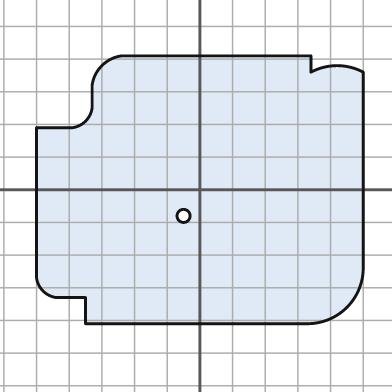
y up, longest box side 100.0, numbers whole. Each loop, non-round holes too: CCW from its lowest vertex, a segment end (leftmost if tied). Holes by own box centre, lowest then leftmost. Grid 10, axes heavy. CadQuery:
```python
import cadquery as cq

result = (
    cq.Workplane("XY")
    .moveTo(-35.0, -41.0)
    .lineTo(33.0, -41.0)
    .threePointArc((45.0, -36.0), (50.0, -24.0))
    .lineTo(50.0, 36.0)
    .threePointArc((42.0, 38.0), (34.0, 36.0))
    .lineTo(34.0, 41.0)
    .lineTo(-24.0, 41.0)
    .threePointArc((-30.0, 38.0), (-33.0, 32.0))
    .lineTo(-33.0, 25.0)
    .threePointArc((-35.0, 21.0), (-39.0, 19.0))
    .lineTo(-50.0, 19.0)
    .lineTo(-50.0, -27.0)
    .threePointArc((-48.0, -31.0), (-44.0, -33.0))
    .lineTo(-35.0, -33.0)
    .close()
    .moveTo(-5.0, -8.0)
    .circle(2.0)
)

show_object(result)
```